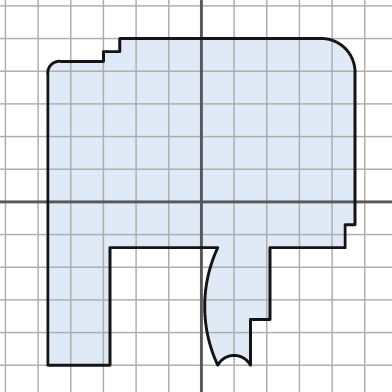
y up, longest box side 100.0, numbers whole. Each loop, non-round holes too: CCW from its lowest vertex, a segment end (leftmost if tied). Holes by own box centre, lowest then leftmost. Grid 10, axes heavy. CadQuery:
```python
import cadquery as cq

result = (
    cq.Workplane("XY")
    .moveTo(-47.0, -50.0)
    .lineTo(-28.0, -50.0)
    .lineTo(-28.0, -14.0)
    .lineTo(5.0, -14.0)
    .threePointArc((1.0, -32.0), (5.0, -50.0))
    .threePointArc((10.0, -47.0), (15.0, -50.0))
    .lineTo(15.0, -36.0)
    .lineTo(21.0, -36.0)
    .lineTo(21.0, -14.0)
    .lineTo(44.0, -14.0)
    .lineTo(44.0, -7.0)
    .lineTo(47.0, -7.0)
    .lineTo(47.0, 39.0)
    .threePointArc((44.0, 47.0), (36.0, 50.0))
    .lineTo(-25.0, 50.0)
    .lineTo(-25.0, 46.0)
    .lineTo(-30.0, 46.0)
    .lineTo(-30.0, 43.0)
    .lineTo(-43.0, 43.0)
    .threePointArc((-46.0, 42.0), (-47.0, 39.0))
    .close()
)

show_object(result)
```